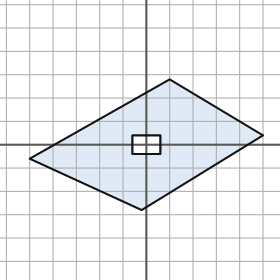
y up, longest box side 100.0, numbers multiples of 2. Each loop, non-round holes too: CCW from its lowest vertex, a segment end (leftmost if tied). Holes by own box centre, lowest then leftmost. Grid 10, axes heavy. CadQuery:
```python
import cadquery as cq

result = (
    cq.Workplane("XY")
    .moveTo(-2.0, -28.0)
    .lineTo(50.0, 4.0)
    .lineTo(10.0, 28.0)
    .lineTo(-50.0, -6.0)
    .close()
    .moveTo(-6.0, -4.0)
    .lineTo(6.0, -4.0)
    .lineTo(6.0, 4.0)
    .lineTo(-6.0, 4.0)
    .close()
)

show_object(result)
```